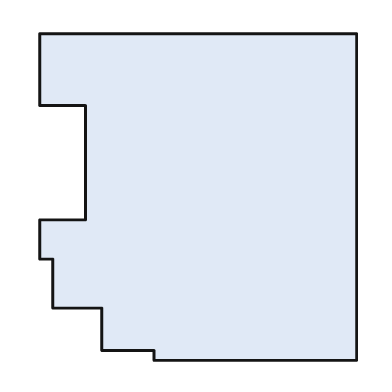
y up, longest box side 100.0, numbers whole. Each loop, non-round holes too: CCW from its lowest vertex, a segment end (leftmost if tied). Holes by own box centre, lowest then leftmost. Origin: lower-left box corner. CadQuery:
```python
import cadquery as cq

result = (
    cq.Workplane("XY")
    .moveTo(35.0, 0.0)
    .lineTo(97.0, 0.0)
    .lineTo(97.0, 100.0)
    .lineTo(0.0, 100.0)
    .lineTo(0.0, 78.0)
    .lineTo(14.0, 78.0)
    .lineTo(14.0, 43.0)
    .lineTo(0.0, 43.0)
    .lineTo(0.0, 31.0)
    .lineTo(4.0, 31.0)
    .lineTo(4.0, 16.0)
    .lineTo(19.0, 16.0)
    .lineTo(19.0, 3.0)
    .lineTo(35.0, 3.0)
    .close()
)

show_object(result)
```